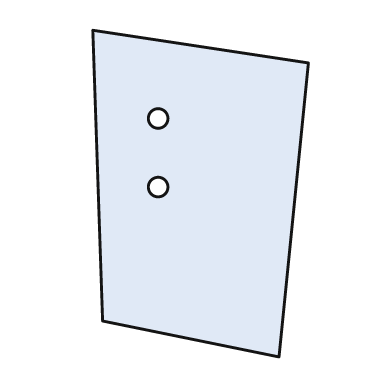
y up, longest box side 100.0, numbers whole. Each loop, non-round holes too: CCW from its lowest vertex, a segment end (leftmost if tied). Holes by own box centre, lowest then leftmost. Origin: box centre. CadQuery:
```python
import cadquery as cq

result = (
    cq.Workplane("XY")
    .moveTo(24.0, -50.0)
    .lineTo(33.0, 40.0)
    .lineTo(-33.0, 50.0)
    .lineTo(-30.0, -39.0)
    .close()
    .moveTo(-13.0, 2.0)
    .circle(3.0)
    .moveTo(-13.0, 23.0)
    .circle(3.0)
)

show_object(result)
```